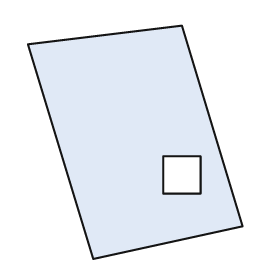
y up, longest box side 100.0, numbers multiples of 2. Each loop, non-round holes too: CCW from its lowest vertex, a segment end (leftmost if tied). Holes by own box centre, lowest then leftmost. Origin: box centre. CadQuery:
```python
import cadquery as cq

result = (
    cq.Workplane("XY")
    .moveTo(-18.0, -50.0)
    .lineTo(46.0, -36.0)
    .lineTo(20.0, 50.0)
    .lineTo(-46.0, 42.0)
    .close()
    .moveTo(12.0, -22.0)
    .lineTo(28.0, -22.0)
    .lineTo(28.0, -6.0)
    .lineTo(12.0, -6.0)
    .close()
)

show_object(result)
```